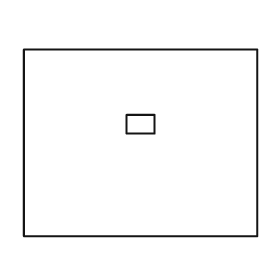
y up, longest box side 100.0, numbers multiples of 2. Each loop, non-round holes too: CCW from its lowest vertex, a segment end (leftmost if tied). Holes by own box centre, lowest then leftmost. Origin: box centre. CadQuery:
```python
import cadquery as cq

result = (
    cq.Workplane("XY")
    .moveTo(-50.0, -40.0)
    .lineTo(50.0, -40.0)
    .lineTo(50.0, 40.0)
    .lineTo(-50.0, 40.0)
    .close()
    .moveTo(-6.0, 4.0)
    .lineTo(6.0, 4.0)
    .lineTo(6.0, 12.0)
    .lineTo(-6.0, 12.0)
    .close()
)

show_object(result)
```